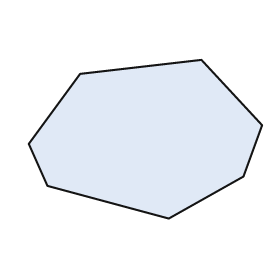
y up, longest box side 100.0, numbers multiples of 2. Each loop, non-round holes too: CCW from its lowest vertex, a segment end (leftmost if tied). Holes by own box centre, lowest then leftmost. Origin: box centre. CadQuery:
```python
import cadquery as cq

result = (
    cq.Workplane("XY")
    .moveTo(10.0, -34.0)
    .lineTo(42.0, -16.0)
    .lineTo(50.0, 6.0)
    .lineTo(24.0, 34.0)
    .lineTo(-28.0, 28.0)
    .lineTo(-50.0, -2.0)
    .lineTo(-42.0, -20.0)
    .close()
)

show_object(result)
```